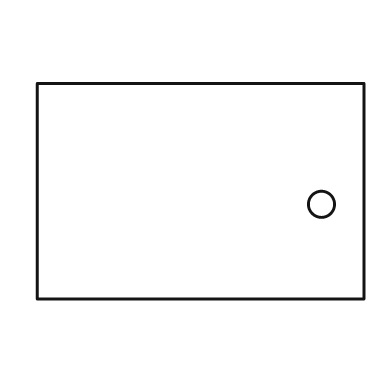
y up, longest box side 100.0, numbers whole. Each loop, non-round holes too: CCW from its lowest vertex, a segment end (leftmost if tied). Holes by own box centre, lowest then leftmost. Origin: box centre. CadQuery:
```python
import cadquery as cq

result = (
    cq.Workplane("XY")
    .moveTo(-50.0, -33.0)
    .lineTo(50.0, -33.0)
    .lineTo(50.0, 33.0)
    .lineTo(-50.0, 33.0)
    .close()
    .moveTo(37.0, -4.0)
    .circle(4.0)
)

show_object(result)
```